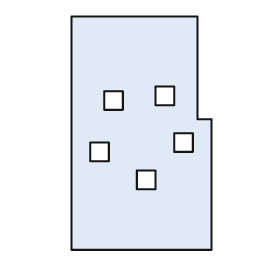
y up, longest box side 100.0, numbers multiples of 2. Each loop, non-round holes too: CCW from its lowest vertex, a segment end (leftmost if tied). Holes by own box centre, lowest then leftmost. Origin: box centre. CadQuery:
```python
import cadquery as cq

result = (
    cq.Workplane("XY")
    .moveTo(-30.0, -50.0)
    .lineTo(30.0, -50.0)
    .lineTo(30.0, 6.0)
    .lineTo(24.0, 6.0)
    .lineTo(24.0, 50.0)
    .lineTo(-30.0, 50.0)
    .close()
    .moveTo(-2.0, -24.0)
    .lineTo(6.0, -24.0)
    .lineTo(6.0, -16.0)
    .lineTo(-2.0, -16.0)
    .close()
    .moveTo(-22.0, -12.0)
    .lineTo(-14.0, -12.0)
    .lineTo(-14.0, -4.0)
    .lineTo(-22.0, -4.0)
    .close()
    .moveTo(14.0, -8.0)
    .lineTo(22.0, -8.0)
    .lineTo(22.0, 0.0)
    .lineTo(14.0, 0.0)
    .close()
    .moveTo(-16.0, 10.0)
    .lineTo(-8.0, 10.0)
    .lineTo(-8.0, 18.0)
    .lineTo(-16.0, 18.0)
    .close()
    .moveTo(6.0, 12.0)
    .lineTo(14.0, 12.0)
    .lineTo(14.0, 20.0)
    .lineTo(6.0, 20.0)
    .close()
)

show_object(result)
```